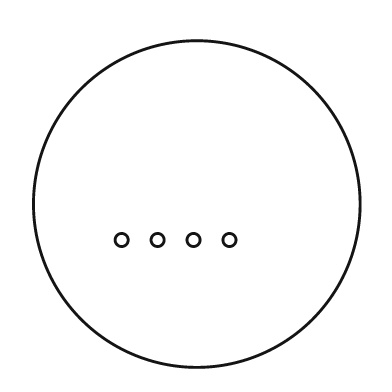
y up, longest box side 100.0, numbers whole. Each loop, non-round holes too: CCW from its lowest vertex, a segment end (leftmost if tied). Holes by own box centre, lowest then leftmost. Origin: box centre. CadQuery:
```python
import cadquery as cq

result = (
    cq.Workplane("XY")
    .moveTo(0.0, 0.0)
    .circle(50.0)
    .moveTo(-23.0, -11.0)
    .circle(2.0)
    .moveTo(-12.0, -11.0)
    .circle(2.0)
    .moveTo(-1.0, -11.0)
    .circle(2.0)
    .moveTo(10.0, -11.0)
    .circle(2.0)
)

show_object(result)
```